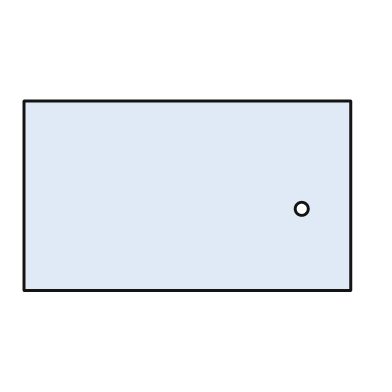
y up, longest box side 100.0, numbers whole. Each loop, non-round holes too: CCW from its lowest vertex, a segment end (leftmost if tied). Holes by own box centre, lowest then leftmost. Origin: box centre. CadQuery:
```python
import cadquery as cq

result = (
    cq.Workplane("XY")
    .moveTo(-50.0, -29.0)
    .lineTo(50.0, -29.0)
    .lineTo(50.0, 29.0)
    .lineTo(-50.0, 29.0)
    .close()
    .moveTo(35.0, -4.0)
    .circle(2.0)
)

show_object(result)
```